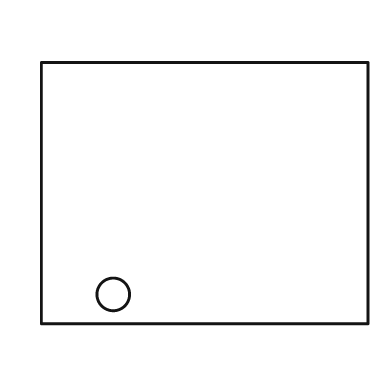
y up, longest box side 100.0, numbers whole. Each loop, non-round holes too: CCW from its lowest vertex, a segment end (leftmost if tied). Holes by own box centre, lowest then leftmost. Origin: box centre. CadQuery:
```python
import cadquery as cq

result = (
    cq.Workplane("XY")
    .moveTo(-50.0, -40.0)
    .lineTo(50.0, -40.0)
    .lineTo(50.0, 40.0)
    .lineTo(-50.0, 40.0)
    .close()
    .moveTo(-28.0, -31.0)
    .circle(5.0)
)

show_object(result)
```